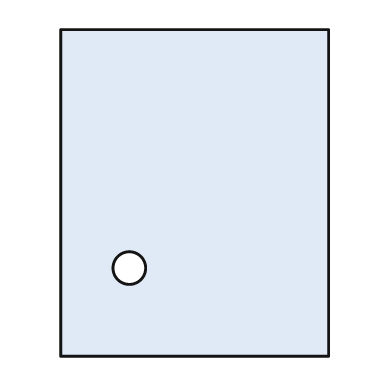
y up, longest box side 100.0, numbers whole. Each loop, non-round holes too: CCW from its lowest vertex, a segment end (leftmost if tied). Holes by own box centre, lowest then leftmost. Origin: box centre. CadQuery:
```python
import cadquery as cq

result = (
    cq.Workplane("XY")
    .moveTo(-41.0, -50.0)
    .lineTo(41.0, -50.0)
    .lineTo(41.0, 50.0)
    .lineTo(-41.0, 50.0)
    .close()
    .moveTo(-20.0, -23.0)
    .circle(5.0)
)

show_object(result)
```